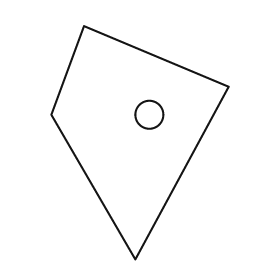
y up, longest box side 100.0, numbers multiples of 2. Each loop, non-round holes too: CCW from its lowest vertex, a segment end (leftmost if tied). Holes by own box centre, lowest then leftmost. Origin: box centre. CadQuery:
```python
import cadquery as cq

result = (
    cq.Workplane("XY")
    .moveTo(-2.0, -50.0)
    .lineTo(38.0, 24.0)
    .lineTo(-24.0, 50.0)
    .lineTo(-38.0, 12.0)
    .close()
    .moveTo(4.0, 12.0)
    .circle(6.0)
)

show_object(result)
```